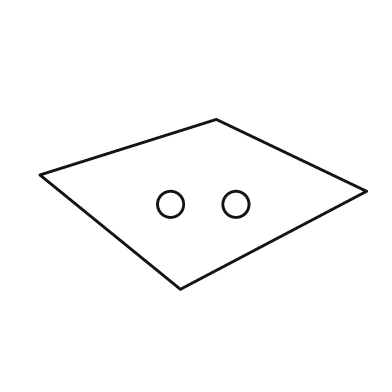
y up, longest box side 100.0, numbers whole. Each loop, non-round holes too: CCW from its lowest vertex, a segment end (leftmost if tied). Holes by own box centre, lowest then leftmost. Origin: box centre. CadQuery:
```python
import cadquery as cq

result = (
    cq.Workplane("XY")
    .moveTo(-7.0, -26.0)
    .lineTo(50.0, 4.0)
    .lineTo(4.0, 26.0)
    .lineTo(-50.0, 9.0)
    .close()
    .moveTo(-10.0, 0.0)
    .circle(4.0)
    .moveTo(10.0, 0.0)
    .circle(4.0)
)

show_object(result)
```